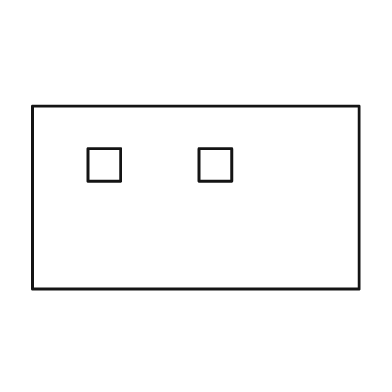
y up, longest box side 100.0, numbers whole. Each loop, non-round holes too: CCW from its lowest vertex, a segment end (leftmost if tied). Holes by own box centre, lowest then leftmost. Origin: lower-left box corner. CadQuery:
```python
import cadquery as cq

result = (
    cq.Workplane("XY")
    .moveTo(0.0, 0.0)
    .lineTo(100.0, 0.0)
    .lineTo(100.0, 56.0)
    .lineTo(0.0, 56.0)
    .close()
    .moveTo(17.0, 33.0)
    .lineTo(27.0, 33.0)
    .lineTo(27.0, 43.0)
    .lineTo(17.0, 43.0)
    .close()
    .moveTo(51.0, 33.0)
    .lineTo(61.0, 33.0)
    .lineTo(61.0, 43.0)
    .lineTo(51.0, 43.0)
    .close()
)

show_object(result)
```